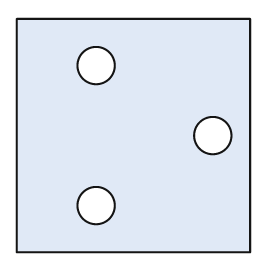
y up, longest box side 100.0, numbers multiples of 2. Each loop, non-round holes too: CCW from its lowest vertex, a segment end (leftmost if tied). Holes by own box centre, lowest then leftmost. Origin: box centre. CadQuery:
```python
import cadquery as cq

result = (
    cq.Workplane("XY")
    .moveTo(-50.0, -50.0)
    .lineTo(50.0, -50.0)
    .lineTo(50.0, 50.0)
    .lineTo(-50.0, 50.0)
    .close()
    .moveTo(-16.0, -30.0)
    .circle(8.0)
    .moveTo(34.0, 0.0)
    .circle(8.0)
    .moveTo(-16.0, 30.0)
    .circle(8.0)
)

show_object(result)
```